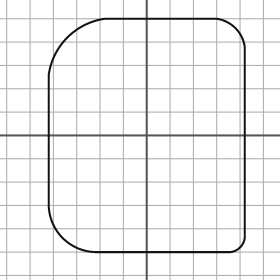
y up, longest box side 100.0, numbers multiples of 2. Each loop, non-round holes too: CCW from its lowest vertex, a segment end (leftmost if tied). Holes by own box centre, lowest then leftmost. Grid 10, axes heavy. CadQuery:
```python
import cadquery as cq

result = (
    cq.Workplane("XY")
    .moveTo(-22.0, -50.0)
    .lineTo(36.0, -50.0)
    .threePointArc((40.0, -48.0), (42.0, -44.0))
    .lineTo(42.0, 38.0)
    .threePointArc((38.0, 46.0), (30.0, 50.0))
    .lineTo(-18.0, 50.0)
    .threePointArc((-34.0, 42.0), (-42.0, 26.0))
    .lineTo(-42.0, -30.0)
    .threePointArc((-36.0, -44.0), (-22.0, -50.0))
    .close()
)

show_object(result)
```